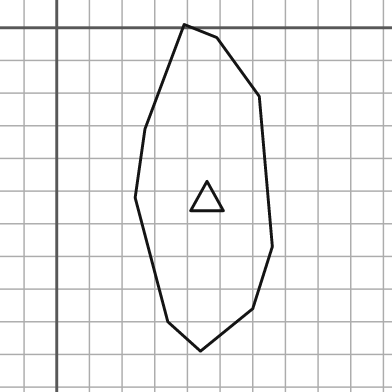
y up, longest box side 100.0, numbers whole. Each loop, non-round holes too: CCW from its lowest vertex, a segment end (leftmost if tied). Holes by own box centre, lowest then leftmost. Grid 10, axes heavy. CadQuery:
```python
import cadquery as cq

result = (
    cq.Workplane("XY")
    .moveTo(44.0, -99.0)
    .lineTo(60.0, -86.0)
    .lineTo(66.0, -67.0)
    .lineTo(62.0, -21.0)
    .lineTo(49.0, -3.0)
    .lineTo(39.0, 1.0)
    .lineTo(27.0, -31.0)
    .lineTo(24.0, -52.0)
    .lineTo(34.0, -90.0)
    .close()
    .moveTo(41.0, -56.0)
    .lineTo(51.0, -56.0)
    .lineTo(46.0, -47.0)
    .close()
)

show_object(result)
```